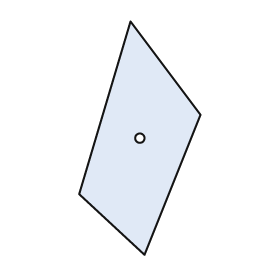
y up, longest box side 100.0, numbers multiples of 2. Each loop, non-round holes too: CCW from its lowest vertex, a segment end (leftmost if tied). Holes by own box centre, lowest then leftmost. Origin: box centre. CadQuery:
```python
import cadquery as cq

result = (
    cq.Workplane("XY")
    .moveTo(2.0, -50.0)
    .lineTo(26.0, 10.0)
    .lineTo(-4.0, 50.0)
    .lineTo(-26.0, -24.0)
    .close()
    .moveTo(0.0, 0.0)
    .circle(2.0)
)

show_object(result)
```